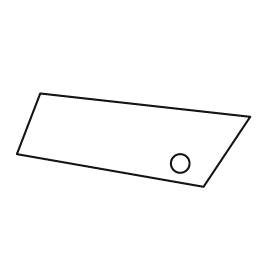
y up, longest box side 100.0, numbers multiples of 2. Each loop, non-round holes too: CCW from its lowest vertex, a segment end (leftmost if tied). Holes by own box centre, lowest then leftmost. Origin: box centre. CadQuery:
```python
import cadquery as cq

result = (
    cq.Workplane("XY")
    .moveTo(30.0, -20.0)
    .lineTo(50.0, 10.0)
    .lineTo(-40.0, 20.0)
    .lineTo(-50.0, -6.0)
    .close()
    .moveTo(20.0, -10.0)
    .circle(4.0)
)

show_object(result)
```